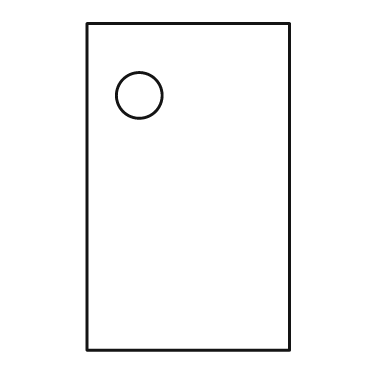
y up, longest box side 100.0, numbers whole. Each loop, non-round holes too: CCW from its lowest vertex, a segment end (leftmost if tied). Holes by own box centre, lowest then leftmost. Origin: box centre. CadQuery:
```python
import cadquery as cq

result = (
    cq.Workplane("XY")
    .moveTo(-31.0, -50.0)
    .lineTo(31.0, -50.0)
    .lineTo(31.0, 50.0)
    .lineTo(-31.0, 50.0)
    .close()
    .moveTo(-15.0, 28.0)
    .circle(7.0)
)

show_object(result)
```